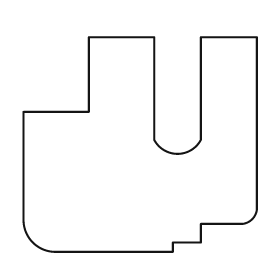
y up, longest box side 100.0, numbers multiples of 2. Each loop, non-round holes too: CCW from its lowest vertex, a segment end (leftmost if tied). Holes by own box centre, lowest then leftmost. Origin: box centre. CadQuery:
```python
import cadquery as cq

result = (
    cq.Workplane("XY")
    .moveTo(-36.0, -46.0)
    .lineTo(14.0, -46.0)
    .lineTo(14.0, -42.0)
    .lineTo(26.0, -42.0)
    .lineTo(26.0, -34.0)
    .lineTo(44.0, -34.0)
    .threePointArc((48.0, -32.0), (50.0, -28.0))
    .lineTo(50.0, 46.0)
    .lineTo(26.0, 46.0)
    .lineTo(26.0, 2.0)
    .threePointArc((16.0, -4.0), (6.0, 2.0))
    .lineTo(6.0, 46.0)
    .lineTo(-22.0, 46.0)
    .lineTo(-22.0, 14.0)
    .lineTo(-50.0, 14.0)
    .lineTo(-50.0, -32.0)
    .threePointArc((-46.0, -42.0), (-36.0, -46.0))
    .close()
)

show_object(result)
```